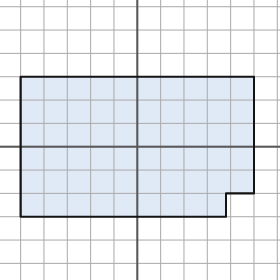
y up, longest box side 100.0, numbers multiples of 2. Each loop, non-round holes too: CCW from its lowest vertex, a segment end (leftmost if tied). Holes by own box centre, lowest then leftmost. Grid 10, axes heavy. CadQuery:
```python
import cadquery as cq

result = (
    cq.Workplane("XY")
    .moveTo(-50.0, -30.0)
    .lineTo(38.0, -30.0)
    .lineTo(38.0, -20.0)
    .lineTo(50.0, -20.0)
    .lineTo(50.0, 30.0)
    .lineTo(-50.0, 30.0)
    .close()
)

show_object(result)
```